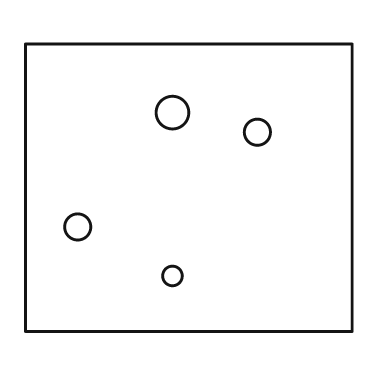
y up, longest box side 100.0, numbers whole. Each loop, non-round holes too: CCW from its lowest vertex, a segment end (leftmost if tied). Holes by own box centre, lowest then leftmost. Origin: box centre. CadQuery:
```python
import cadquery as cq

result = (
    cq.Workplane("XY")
    .moveTo(-50.0, -44.0)
    .lineTo(50.0, -44.0)
    .lineTo(50.0, 44.0)
    .lineTo(-50.0, 44.0)
    .close()
    .moveTo(-5.0, -27.0)
    .circle(3.0)
    .moveTo(-34.0, -12.0)
    .circle(4.0)
    .moveTo(21.0, 17.0)
    .circle(4.0)
    .moveTo(-5.0, 23.0)
    .circle(5.0)
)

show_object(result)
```